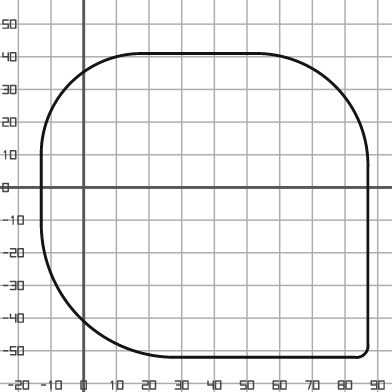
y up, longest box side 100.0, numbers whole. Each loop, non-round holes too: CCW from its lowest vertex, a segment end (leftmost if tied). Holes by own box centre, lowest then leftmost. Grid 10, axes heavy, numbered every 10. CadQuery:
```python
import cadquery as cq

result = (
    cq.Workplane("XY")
    .moveTo(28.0, -52.0)
    .lineTo(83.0, -52.0)
    .threePointArc((86.0, -51.0), (87.0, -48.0))
    .lineTo(87.0, 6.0)
    .threePointArc((77.0, 31.0), (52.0, 41.0))
    .lineTo(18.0, 41.0)
    .threePointArc((-4.0, 32.0), (-13.0, 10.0))
    .lineTo(-13.0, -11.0)
    .threePointArc((-1.0, -40.0), (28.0, -52.0))
    .close()
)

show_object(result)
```